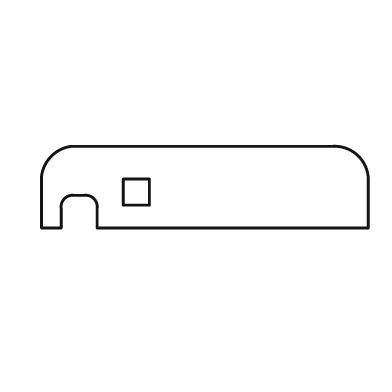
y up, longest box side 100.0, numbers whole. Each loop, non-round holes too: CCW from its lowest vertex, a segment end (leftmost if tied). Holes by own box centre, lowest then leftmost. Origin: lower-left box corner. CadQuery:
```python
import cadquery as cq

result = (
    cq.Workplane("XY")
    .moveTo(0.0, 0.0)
    .lineTo(6.0, 0.0)
    .lineTo(6.0, 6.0)
    .threePointArc((7.0, 9.0), (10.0, 10.0))
    .lineTo(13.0, 10.0)
    .threePointArc((16.0, 9.0), (17.0, 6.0))
    .lineTo(17.0, 0.0)
    .lineTo(100.0, 0.0)
    .lineTo(100.0, 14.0)
    .threePointArc((97.0, 22.0), (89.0, 25.0))
    .lineTo(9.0, 25.0)
    .threePointArc((3.0, 22.0), (0.0, 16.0))
    .close()
    .moveTo(25.0, 7.0)
    .lineTo(33.0, 7.0)
    .lineTo(33.0, 15.0)
    .lineTo(25.0, 15.0)
    .close()
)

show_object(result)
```